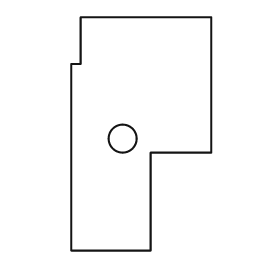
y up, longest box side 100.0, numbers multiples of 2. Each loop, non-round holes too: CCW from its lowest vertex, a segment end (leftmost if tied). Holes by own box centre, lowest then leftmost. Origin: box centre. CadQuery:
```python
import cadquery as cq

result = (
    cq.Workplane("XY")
    .moveTo(-30.0, -50.0)
    .lineTo(4.0, -50.0)
    .lineTo(4.0, -8.0)
    .lineTo(30.0, -8.0)
    .lineTo(30.0, 50.0)
    .lineTo(-26.0, 50.0)
    .lineTo(-26.0, 30.0)
    .lineTo(-30.0, 30.0)
    .close()
    .moveTo(-8.0, -2.0)
    .circle(6.0)
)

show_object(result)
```